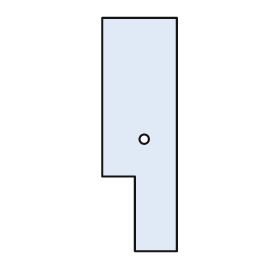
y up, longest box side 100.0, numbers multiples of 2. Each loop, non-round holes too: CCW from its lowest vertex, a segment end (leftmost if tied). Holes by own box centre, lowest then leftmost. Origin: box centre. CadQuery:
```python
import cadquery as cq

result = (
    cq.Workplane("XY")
    .moveTo(-2.0, -50.0)
    .lineTo(16.0, -50.0)
    .lineTo(16.0, 50.0)
    .lineTo(-16.0, 50.0)
    .lineTo(-16.0, -18.0)
    .lineTo(-2.0, -18.0)
    .close()
    .moveTo(2.0, -2.0)
    .circle(2.0)
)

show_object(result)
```